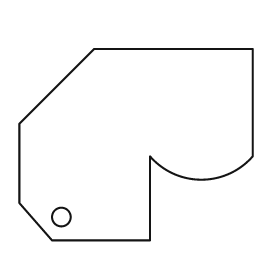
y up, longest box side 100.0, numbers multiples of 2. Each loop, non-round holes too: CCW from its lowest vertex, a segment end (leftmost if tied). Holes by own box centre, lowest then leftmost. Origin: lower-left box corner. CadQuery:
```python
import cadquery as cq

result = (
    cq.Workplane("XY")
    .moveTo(14.0, 0.0)
    .lineTo(56.0, 0.0)
    .lineTo(56.0, 36.0)
    .threePointArc((78.0, 26.0), (100.0, 36.0))
    .lineTo(100.0, 82.0)
    .lineTo(32.0, 82.0)
    .lineTo(0.0, 50.0)
    .lineTo(0.0, 16.0)
    .close()
    .moveTo(18.0, 10.0)
    .circle(4.0)
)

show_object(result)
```